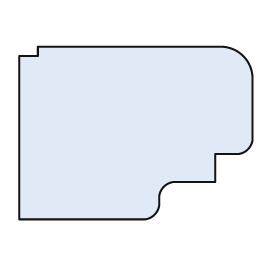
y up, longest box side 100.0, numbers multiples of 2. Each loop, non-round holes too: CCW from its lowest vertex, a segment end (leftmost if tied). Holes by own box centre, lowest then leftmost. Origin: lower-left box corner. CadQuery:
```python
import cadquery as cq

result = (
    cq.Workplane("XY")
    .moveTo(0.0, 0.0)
    .lineTo(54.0, 0.0)
    .threePointArc((58.0, 2.0), (60.0, 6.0))
    .lineTo(60.0, 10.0)
    .threePointArc((62.0, 14.0), (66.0, 16.0))
    .lineTo(84.0, 16.0)
    .lineTo(84.0, 28.0)
    .lineTo(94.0, 28.0)
    .threePointArc((98.0, 30.0), (100.0, 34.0))
    .lineTo(100.0, 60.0)
    .threePointArc((96.0, 70.0), (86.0, 74.0))
    .lineTo(8.0, 74.0)
    .lineTo(8.0, 70.0)
    .lineTo(0.0, 70.0)
    .close()
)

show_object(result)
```